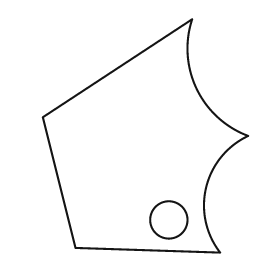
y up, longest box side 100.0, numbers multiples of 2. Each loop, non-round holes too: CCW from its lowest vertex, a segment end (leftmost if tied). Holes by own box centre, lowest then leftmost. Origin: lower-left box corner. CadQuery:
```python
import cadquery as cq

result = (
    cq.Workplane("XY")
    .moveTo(76.0, 0.0)
    .threePointArc((70.0, 28.0), (88.0, 50.0))
    .threePointArc((66.0, 70.0), (64.0, 100.0))
    .lineTo(0.0, 58.0)
    .lineTo(14.0, 2.0)
    .close()
    .moveTo(54.0, 14.0)
    .circle(8.0)
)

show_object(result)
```